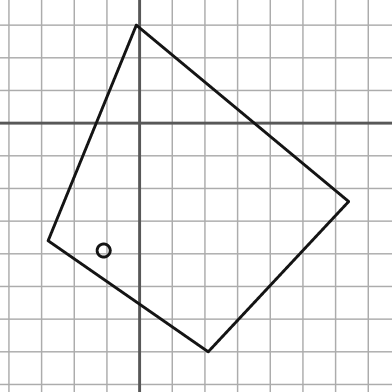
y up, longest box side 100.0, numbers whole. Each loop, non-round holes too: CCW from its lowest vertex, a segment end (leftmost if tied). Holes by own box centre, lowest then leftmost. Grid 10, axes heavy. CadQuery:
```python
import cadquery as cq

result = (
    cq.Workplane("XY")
    .moveTo(21.0, -70.0)
    .lineTo(64.0, -24.0)
    .lineTo(-1.0, 30.0)
    .lineTo(-28.0, -36.0)
    .close()
    .moveTo(-11.0, -39.0)
    .circle(2.0)
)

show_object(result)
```